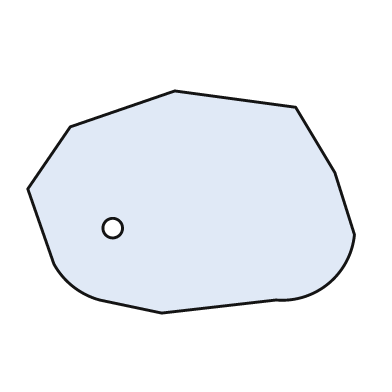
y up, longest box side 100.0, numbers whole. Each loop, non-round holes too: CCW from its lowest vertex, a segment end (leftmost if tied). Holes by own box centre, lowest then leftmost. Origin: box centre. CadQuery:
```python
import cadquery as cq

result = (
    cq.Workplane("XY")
    .moveTo(-9.0, -34.0)
    .lineTo(26.0, -30.0)
    .threePointArc((42.0, -25.0), (50.0, -10.0))
    .lineTo(44.0, 9.0)
    .lineTo(32.0, 29.0)
    .lineTo(-5.0, 34.0)
    .lineTo(-37.0, 23.0)
    .lineTo(-50.0, 4.0)
    .lineTo(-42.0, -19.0)
    .threePointArc((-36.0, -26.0), (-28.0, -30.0))
    .close()
    .moveTo(-24.0, -8.0)
    .circle(3.0)
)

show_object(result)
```